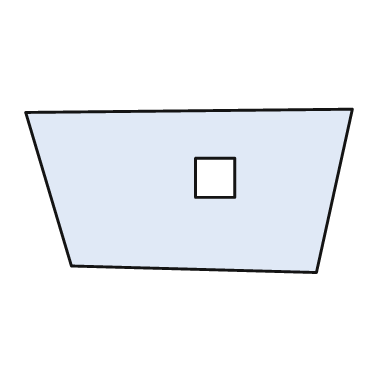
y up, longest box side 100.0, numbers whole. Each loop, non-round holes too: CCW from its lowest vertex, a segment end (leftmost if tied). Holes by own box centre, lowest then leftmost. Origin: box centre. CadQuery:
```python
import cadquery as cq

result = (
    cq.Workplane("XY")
    .moveTo(39.0, -25.0)
    .lineTo(50.0, 25.0)
    .lineTo(-50.0, 24.0)
    .lineTo(-36.0, -23.0)
    .close()
    .moveTo(2.0, -2.0)
    .lineTo(14.0, -2.0)
    .lineTo(14.0, 10.0)
    .lineTo(2.0, 10.0)
    .close()
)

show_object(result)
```